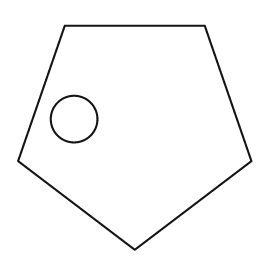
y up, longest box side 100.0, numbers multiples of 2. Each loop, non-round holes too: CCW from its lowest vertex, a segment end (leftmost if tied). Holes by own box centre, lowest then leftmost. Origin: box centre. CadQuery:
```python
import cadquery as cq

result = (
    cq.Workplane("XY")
    .moveTo(0.0, -48.0)
    .lineTo(50.0, -10.0)
    .lineTo(30.0, 48.0)
    .lineTo(-30.0, 48.0)
    .lineTo(-50.0, -10.0)
    .close()
    .moveTo(-26.0, 8.0)
    .circle(10.0)
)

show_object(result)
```